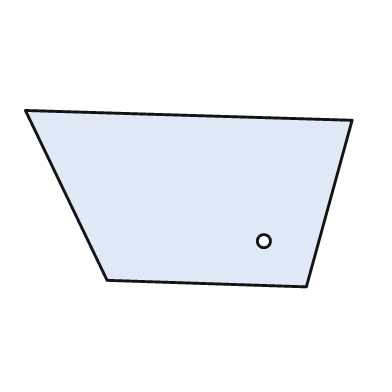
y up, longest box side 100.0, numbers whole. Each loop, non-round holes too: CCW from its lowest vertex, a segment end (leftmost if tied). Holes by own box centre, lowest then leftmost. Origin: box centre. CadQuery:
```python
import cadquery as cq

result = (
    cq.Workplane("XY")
    .moveTo(36.0, -27.0)
    .lineTo(50.0, 24.0)
    .lineTo(-50.0, 27.0)
    .lineTo(-25.0, -25.0)
    .close()
    .moveTo(23.0, -13.0)
    .circle(2.0)
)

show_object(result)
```